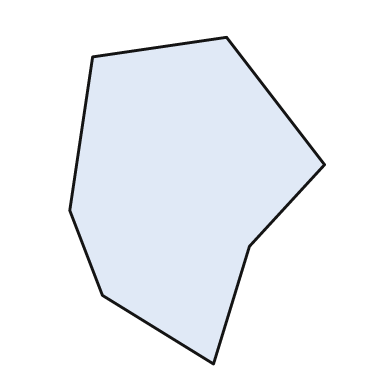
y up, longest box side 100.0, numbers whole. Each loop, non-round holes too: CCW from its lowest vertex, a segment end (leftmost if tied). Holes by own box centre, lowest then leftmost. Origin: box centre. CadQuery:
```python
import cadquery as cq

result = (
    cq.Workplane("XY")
    .moveTo(5.0, -50.0)
    .lineTo(16.0, -14.0)
    .lineTo(39.0, 11.0)
    .lineTo(9.0, 50.0)
    .lineTo(-32.0, 44.0)
    .lineTo(-39.0, -3.0)
    .lineTo(-29.0, -29.0)
    .close()
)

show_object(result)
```